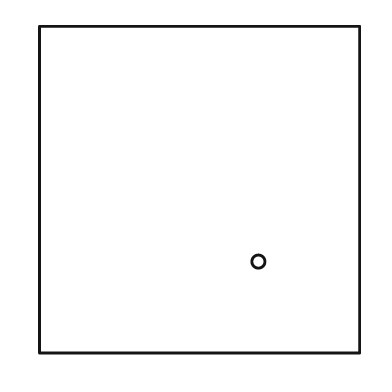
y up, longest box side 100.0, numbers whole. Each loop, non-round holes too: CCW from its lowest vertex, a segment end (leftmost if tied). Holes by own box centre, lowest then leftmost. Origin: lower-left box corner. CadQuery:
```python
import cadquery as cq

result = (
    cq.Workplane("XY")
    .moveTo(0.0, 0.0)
    .lineTo(98.0, 0.0)
    .lineTo(98.0, 100.0)
    .lineTo(0.0, 100.0)
    .close()
    .moveTo(67.0, 28.0)
    .circle(2.0)
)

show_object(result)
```